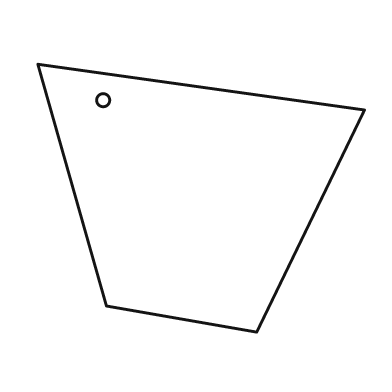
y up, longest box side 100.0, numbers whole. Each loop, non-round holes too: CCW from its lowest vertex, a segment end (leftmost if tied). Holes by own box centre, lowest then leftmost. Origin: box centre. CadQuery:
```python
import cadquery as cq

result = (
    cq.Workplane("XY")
    .moveTo(17.0, -41.0)
    .lineTo(50.0, 27.0)
    .lineTo(-50.0, 41.0)
    .lineTo(-29.0, -33.0)
    .close()
    .moveTo(-30.0, 30.0)
    .circle(2.0)
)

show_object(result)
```